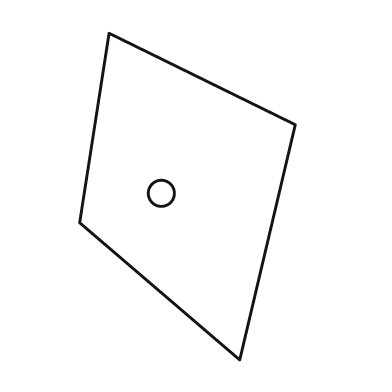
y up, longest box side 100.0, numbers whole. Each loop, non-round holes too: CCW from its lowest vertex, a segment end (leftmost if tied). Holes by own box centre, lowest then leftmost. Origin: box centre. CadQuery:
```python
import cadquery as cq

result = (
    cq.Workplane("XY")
    .moveTo(16.0, -50.0)
    .lineTo(33.0, 22.0)
    .lineTo(-24.0, 50.0)
    .lineTo(-33.0, -8.0)
    .close()
    .moveTo(-8.0, 1.0)
    .circle(4.0)
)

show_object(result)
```